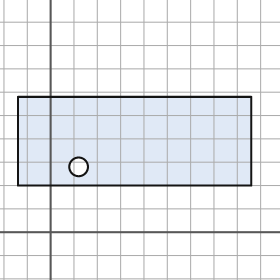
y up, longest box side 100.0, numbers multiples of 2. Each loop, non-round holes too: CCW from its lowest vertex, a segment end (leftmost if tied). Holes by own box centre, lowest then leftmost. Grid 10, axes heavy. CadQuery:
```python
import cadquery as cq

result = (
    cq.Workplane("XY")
    .moveTo(-14.0, 20.0)
    .lineTo(86.0, 20.0)
    .lineTo(86.0, 58.0)
    .lineTo(-14.0, 58.0)
    .close()
    .moveTo(12.0, 28.0)
    .circle(4.0)
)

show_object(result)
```